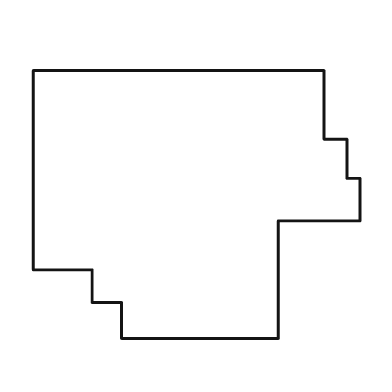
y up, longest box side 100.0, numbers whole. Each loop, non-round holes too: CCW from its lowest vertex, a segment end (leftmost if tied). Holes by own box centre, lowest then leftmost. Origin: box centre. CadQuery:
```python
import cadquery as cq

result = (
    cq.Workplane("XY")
    .moveTo(-23.0, -41.0)
    .lineTo(25.0, -41.0)
    .lineTo(25.0, -5.0)
    .lineTo(50.0, -5.0)
    .lineTo(50.0, 8.0)
    .lineTo(46.0, 8.0)
    .lineTo(46.0, 20.0)
    .lineTo(39.0, 20.0)
    .lineTo(39.0, 41.0)
    .lineTo(-50.0, 41.0)
    .lineTo(-50.0, -20.0)
    .lineTo(-32.0, -20.0)
    .lineTo(-32.0, -30.0)
    .lineTo(-23.0, -30.0)
    .close()
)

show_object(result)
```